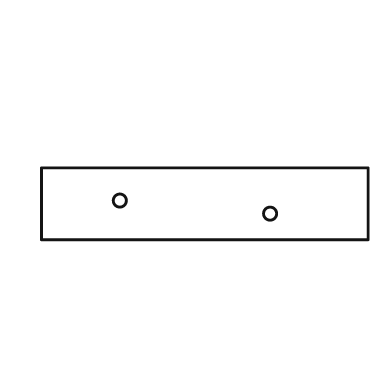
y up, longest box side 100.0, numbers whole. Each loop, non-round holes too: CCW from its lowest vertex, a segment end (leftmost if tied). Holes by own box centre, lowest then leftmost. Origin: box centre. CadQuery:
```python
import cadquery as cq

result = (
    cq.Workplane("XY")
    .moveTo(-50.0, -11.0)
    .lineTo(50.0, -11.0)
    .lineTo(50.0, 11.0)
    .lineTo(-50.0, 11.0)
    .close()
    .moveTo(20.0, -3.0)
    .circle(2.0)
    .moveTo(-26.0, 1.0)
    .circle(2.0)
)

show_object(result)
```